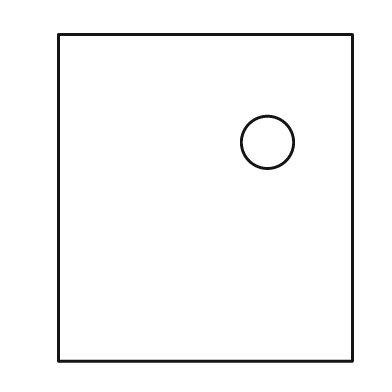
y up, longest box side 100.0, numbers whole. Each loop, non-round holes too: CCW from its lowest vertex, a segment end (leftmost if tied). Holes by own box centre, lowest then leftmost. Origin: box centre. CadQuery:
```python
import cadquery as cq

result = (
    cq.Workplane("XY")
    .moveTo(-45.0, -50.0)
    .lineTo(45.0, -50.0)
    .lineTo(45.0, 50.0)
    .lineTo(-45.0, 50.0)
    .close()
    .moveTo(19.0, 17.0)
    .circle(8.0)
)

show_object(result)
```